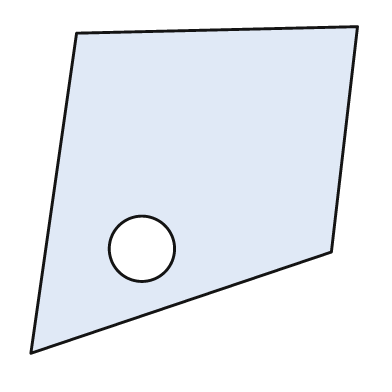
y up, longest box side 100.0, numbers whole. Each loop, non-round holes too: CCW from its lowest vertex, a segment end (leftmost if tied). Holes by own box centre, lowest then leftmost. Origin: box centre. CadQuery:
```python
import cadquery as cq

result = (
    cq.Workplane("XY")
    .moveTo(-50.0, -50.0)
    .lineTo(42.0, -19.0)
    .lineTo(50.0, 50.0)
    .lineTo(-36.0, 48.0)
    .close()
    .moveTo(-16.0, -18.0)
    .circle(10.0)
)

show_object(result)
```